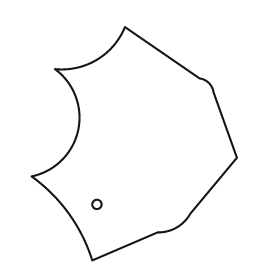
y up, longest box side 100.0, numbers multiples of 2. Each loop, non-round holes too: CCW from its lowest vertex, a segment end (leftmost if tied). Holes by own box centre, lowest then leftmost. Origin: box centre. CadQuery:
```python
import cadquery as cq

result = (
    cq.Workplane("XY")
    .moveTo(-18.0, -50.0)
    .lineTo(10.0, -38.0)
    .threePointArc((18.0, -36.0), (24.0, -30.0))
    .lineTo(44.0, -6.0)
    .lineTo(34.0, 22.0)
    .threePointArc((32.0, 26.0), (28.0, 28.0))
    .lineTo(-4.0, 50.0)
    .threePointArc((-16.0, 36.0), (-34.0, 32.0))
    .threePointArc((-24.0, 6.0), (-44.0, -14.0))
    .threePointArc((-28.0, -30.0), (-18.0, -50.0))
    .close()
    .moveTo(-16.0, -26.0)
    .circle(2.0)
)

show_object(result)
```